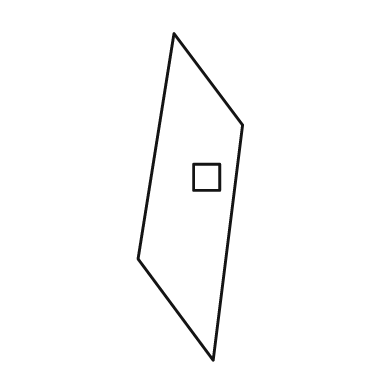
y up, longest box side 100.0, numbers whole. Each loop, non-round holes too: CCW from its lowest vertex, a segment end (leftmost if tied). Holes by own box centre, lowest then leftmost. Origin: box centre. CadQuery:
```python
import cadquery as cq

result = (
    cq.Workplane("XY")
    .moveTo(7.0, -50.0)
    .lineTo(16.0, 22.0)
    .lineTo(-5.0, 50.0)
    .lineTo(-16.0, -19.0)
    .close()
    .moveTo(1.0, 2.0)
    .lineTo(9.0, 2.0)
    .lineTo(9.0, 10.0)
    .lineTo(1.0, 10.0)
    .close()
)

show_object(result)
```